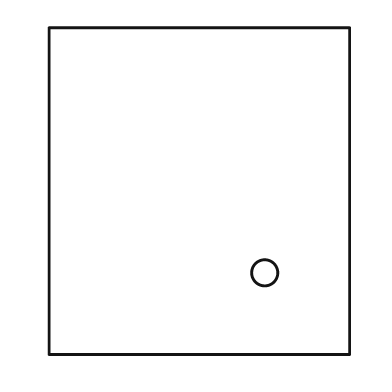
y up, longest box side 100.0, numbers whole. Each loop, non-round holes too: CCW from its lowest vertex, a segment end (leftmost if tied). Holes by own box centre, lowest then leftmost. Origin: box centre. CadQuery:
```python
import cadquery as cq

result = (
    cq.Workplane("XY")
    .moveTo(-46.0, -50.0)
    .lineTo(46.0, -50.0)
    .lineTo(46.0, 50.0)
    .lineTo(-46.0, 50.0)
    .close()
    .moveTo(20.0, -25.0)
    .circle(4.0)
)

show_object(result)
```